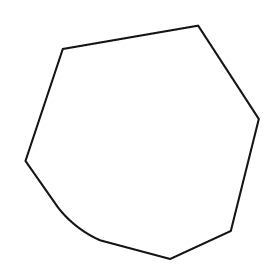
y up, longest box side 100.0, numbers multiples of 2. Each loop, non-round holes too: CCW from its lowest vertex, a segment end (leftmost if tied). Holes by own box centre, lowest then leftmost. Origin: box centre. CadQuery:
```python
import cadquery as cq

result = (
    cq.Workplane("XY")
    .moveTo(12.0, -50.0)
    .lineTo(38.0, -38.0)
    .lineTo(50.0, 10.0)
    .lineTo(24.0, 50.0)
    .lineTo(-34.0, 40.0)
    .lineTo(-50.0, -8.0)
    .lineTo(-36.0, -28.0)
    .threePointArc((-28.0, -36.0), (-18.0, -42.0))
    .close()
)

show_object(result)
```